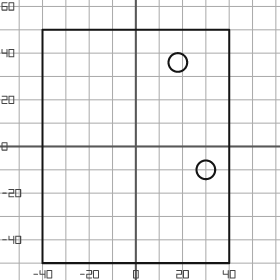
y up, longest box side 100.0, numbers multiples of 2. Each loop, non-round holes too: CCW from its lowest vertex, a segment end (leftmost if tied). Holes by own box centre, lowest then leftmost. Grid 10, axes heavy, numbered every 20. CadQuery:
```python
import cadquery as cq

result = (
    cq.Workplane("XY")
    .moveTo(-40.0, -50.0)
    .lineTo(40.0, -50.0)
    .lineTo(40.0, 50.0)
    .lineTo(-40.0, 50.0)
    .close()
    .moveTo(30.0, -10.0)
    .circle(4.0)
    .moveTo(18.0, 36.0)
    .circle(4.0)
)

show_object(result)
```